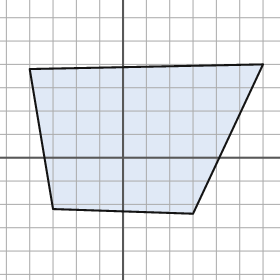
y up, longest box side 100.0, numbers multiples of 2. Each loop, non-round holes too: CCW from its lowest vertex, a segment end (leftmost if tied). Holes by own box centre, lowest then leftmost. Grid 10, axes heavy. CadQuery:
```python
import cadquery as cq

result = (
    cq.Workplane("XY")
    .moveTo(30.0, -24.0)
    .lineTo(60.0, 40.0)
    .lineTo(-40.0, 38.0)
    .lineTo(-30.0, -22.0)
    .close()
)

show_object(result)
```